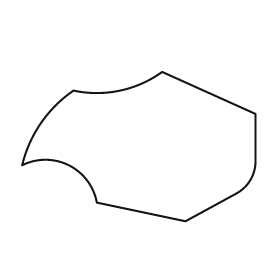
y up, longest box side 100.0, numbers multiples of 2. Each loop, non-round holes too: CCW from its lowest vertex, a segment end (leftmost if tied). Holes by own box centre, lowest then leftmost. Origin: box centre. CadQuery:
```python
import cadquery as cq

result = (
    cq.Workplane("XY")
    .moveTo(20.0, -32.0)
    .lineTo(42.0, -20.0)
    .threePointArc((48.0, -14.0), (50.0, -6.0))
    .lineTo(50.0, 14.0)
    .lineTo(10.0, 32.0)
    .threePointArc((-8.0, 24.0), (-28.0, 24.0))
    .threePointArc((-42.0, 10.0), (-50.0, -8.0))
    .threePointArc((-30.0, -8.0), (-18.0, -24.0))
    .close()
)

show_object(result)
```